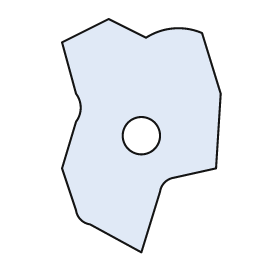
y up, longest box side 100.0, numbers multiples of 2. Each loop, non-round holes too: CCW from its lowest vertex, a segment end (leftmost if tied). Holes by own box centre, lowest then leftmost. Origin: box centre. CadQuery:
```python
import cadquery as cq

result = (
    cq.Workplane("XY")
    .moveTo(0.0, -50.0)
    .lineTo(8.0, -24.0)
    .threePointArc((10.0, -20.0), (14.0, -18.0))
    .lineTo(32.0, -14.0)
    .lineTo(34.0, 18.0)
    .lineTo(26.0, 44.0)
    .threePointArc((14.0, 46.0), (2.0, 42.0))
    .lineTo(-14.0, 50.0)
    .lineTo(-34.0, 40.0)
    .lineTo(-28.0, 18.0)
    .threePointArc((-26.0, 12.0), (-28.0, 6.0))
    .lineTo(-34.0, -14.0)
    .lineTo(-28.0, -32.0)
    .threePointArc((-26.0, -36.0), (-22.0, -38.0))
    .close()
    .moveTo(0.0, 0.0)
    .circle(8.0)
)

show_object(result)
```